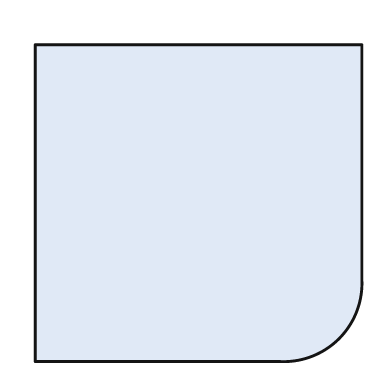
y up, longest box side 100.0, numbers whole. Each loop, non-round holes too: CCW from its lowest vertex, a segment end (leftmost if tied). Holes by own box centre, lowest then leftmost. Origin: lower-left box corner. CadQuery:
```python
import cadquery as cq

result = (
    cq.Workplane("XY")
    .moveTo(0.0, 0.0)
    .lineTo(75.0, 0.0)
    .threePointArc((93.0, 7.0), (100.0, 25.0))
    .lineTo(100.0, 97.0)
    .lineTo(0.0, 97.0)
    .close()
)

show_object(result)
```